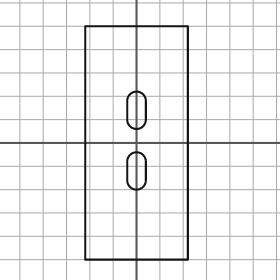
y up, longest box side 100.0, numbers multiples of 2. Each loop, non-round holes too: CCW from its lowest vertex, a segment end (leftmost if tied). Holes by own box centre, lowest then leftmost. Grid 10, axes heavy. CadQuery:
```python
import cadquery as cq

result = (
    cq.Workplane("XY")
    .moveTo(-22.0, -50.0)
    .lineTo(22.0, -50.0)
    .lineTo(22.0, 50.0)
    .lineTo(-22.0, 50.0)
    .close()
    .moveTo(-4.0, -16.0)
    .threePointArc((0.0, -20.0), (4.0, -16.0))
    .lineTo(4.0, -8.0)
    .threePointArc((0.0, -4.0), (-4.0, -8.0))
    .close()
    .moveTo(-4.0, 10.0)
    .threePointArc((0.0, 6.0), (4.0, 10.0))
    .lineTo(4.0, 18.0)
    .threePointArc((0.0, 22.0), (-4.0, 18.0))
    .close()
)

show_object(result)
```